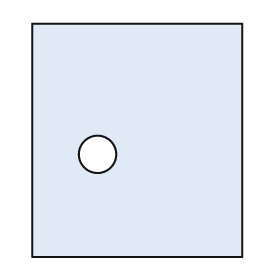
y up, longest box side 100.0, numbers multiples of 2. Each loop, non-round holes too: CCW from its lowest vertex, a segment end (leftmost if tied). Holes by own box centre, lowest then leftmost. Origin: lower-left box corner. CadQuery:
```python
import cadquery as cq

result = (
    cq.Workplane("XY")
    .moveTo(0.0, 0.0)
    .lineTo(90.0, 0.0)
    .lineTo(90.0, 100.0)
    .lineTo(0.0, 100.0)
    .close()
    .moveTo(28.0, 44.0)
    .circle(8.0)
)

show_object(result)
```